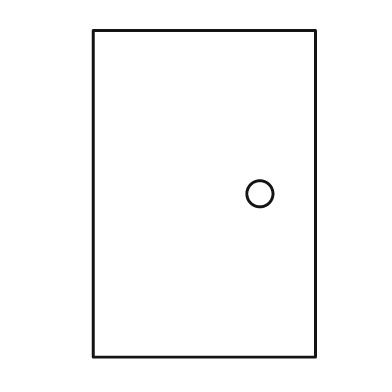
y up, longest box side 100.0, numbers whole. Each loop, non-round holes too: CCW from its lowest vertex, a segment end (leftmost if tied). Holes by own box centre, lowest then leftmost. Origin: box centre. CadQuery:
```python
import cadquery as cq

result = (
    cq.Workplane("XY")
    .moveTo(-34.0, -50.0)
    .lineTo(34.0, -50.0)
    .lineTo(34.0, 50.0)
    .lineTo(-34.0, 50.0)
    .close()
    .moveTo(17.0, 0.0)
    .circle(4.0)
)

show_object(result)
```